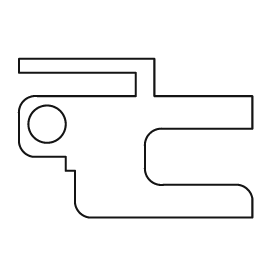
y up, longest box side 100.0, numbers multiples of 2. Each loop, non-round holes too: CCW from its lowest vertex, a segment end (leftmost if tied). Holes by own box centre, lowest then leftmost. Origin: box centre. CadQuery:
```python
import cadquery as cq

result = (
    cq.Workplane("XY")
    .moveTo(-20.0, -34.0)
    .lineTo(50.0, -34.0)
    .lineTo(50.0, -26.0)
    .threePointArc((48.0, -22.0), (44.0, -20.0))
    .lineTo(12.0, -20.0)
    .threePointArc((6.0, -18.0), (4.0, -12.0))
    .lineTo(4.0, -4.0)
    .threePointArc((6.0, 2.0), (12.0, 4.0))
    .lineTo(50.0, 4.0)
    .lineTo(50.0, 18.0)
    .lineTo(8.0, 18.0)
    .lineTo(8.0, 34.0)
    .lineTo(-50.0, 34.0)
    .lineTo(-50.0, 28.0)
    .lineTo(0.0, 28.0)
    .lineTo(0.0, 18.0)
    .lineTo(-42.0, 18.0)
    .threePointArc((-48.0, 16.0), (-50.0, 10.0))
    .lineTo(-50.0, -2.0)
    .threePointArc((-48.0, -6.0), (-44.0, -8.0))
    .lineTo(-30.0, -8.0)
    .lineTo(-30.0, -14.0)
    .lineTo(-26.0, -14.0)
    .lineTo(-26.0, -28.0)
    .threePointArc((-24.0, -32.0), (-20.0, -34.0))
    .close()
    .moveTo(-38.0, 6.0)
    .circle(8.0)
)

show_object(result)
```